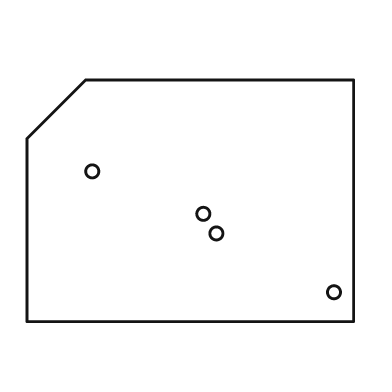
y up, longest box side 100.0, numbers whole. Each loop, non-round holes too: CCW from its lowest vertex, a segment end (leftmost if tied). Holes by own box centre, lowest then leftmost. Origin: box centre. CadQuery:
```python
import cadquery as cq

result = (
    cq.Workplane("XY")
    .moveTo(-50.0, -37.0)
    .lineTo(50.0, -37.0)
    .lineTo(50.0, 37.0)
    .lineTo(-32.0, 37.0)
    .lineTo(-50.0, 19.0)
    .close()
    .moveTo(44.0, -28.0)
    .circle(2.0)
    .moveTo(8.0, -10.0)
    .circle(2.0)
    .moveTo(4.0, -4.0)
    .circle(2.0)
    .moveTo(-30.0, 9.0)
    .circle(2.0)
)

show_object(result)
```